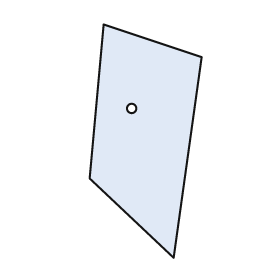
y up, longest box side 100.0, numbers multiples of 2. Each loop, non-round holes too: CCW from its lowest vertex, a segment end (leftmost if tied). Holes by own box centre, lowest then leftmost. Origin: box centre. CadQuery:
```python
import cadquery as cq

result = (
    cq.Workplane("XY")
    .moveTo(12.0, -50.0)
    .lineTo(24.0, 36.0)
    .lineTo(-18.0, 50.0)
    .lineTo(-24.0, -16.0)
    .close()
    .moveTo(-6.0, 14.0)
    .circle(2.0)
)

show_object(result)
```